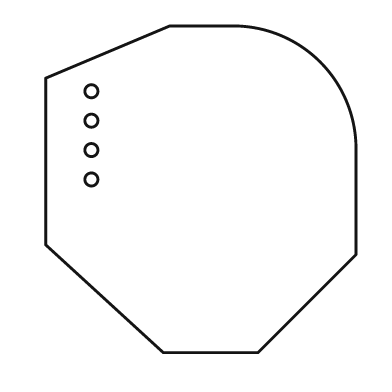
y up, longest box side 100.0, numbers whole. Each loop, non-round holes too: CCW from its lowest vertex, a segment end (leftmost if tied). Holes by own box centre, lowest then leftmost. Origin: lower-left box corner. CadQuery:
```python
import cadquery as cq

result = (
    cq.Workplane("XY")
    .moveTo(36.0, 0.0)
    .lineTo(65.0, 0.0)
    .lineTo(95.0, 30.0)
    .lineTo(95.0, 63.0)
    .threePointArc((84.0, 89.0), (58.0, 100.0))
    .lineTo(38.0, 100.0)
    .lineTo(0.0, 84.0)
    .lineTo(0.0, 33.0)
    .close()
    .moveTo(14.0, 53.0)
    .circle(2.0)
    .moveTo(14.0, 62.0)
    .circle(2.0)
    .moveTo(14.0, 71.0)
    .circle(2.0)
    .moveTo(14.0, 80.0)
    .circle(2.0)
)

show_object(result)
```